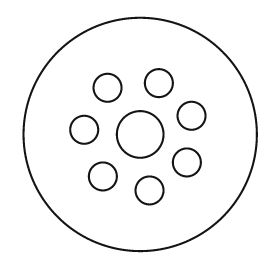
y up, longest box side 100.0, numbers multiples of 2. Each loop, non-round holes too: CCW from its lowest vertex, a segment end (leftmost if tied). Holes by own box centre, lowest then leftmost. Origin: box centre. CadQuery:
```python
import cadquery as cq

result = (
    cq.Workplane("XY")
    .moveTo(0.0, 0.0)
    .circle(50.0)
    .moveTo(4.0, -24.0)
    .circle(6.0)
    .moveTo(-16.0, -18.0)
    .circle(6.0)
    .moveTo(20.0, -12.0)
    .circle(6.0)
    .moveTo(0.0, 0.0)
    .circle(10.0)
    .moveTo(-24.0, 2.0)
    .circle(6.0)
    .moveTo(22.0, 8.0)
    .circle(6.0)
    .moveTo(-14.0, 20.0)
    .circle(6.0)
    .moveTo(8.0, 22.0)
    .circle(6.0)
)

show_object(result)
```